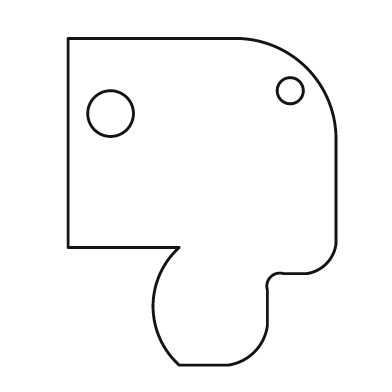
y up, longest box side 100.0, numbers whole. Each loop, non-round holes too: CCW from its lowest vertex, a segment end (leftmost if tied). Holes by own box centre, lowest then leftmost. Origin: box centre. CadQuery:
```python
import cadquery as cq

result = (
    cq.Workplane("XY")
    .moveTo(-7.0, -50.0)
    .lineTo(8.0, -50.0)
    .threePointArc((16.0, -46.0), (20.0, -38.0))
    .lineTo(20.0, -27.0)
    .threePointArc((21.0, -23.0), (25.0, -22.0))
    .lineTo(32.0, -22.0)
    .threePointArc((38.0, -19.0), (41.0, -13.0))
    .lineTo(41.0, 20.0)
    .threePointArc((32.0, 41.0), (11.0, 50.0))
    .lineTo(-41.0, 50.0)
    .lineTo(-41.0, -14.0)
    .lineTo(-7.0, -14.0)
    .threePointArc((-15.0, -32.0), (-7.0, -50.0))
    .close()
    .moveTo(-28.0, 27.0)
    .circle(7.0)
    .moveTo(27.0, 34.0)
    .circle(4.0)
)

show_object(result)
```